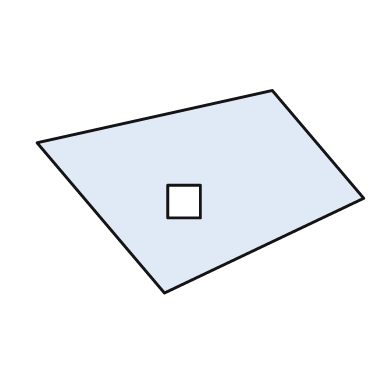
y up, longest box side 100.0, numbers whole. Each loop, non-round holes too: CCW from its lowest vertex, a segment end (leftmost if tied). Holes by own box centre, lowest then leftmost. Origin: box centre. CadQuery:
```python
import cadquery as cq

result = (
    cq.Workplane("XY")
    .moveTo(-11.0, -31.0)
    .lineTo(50.0, -2.0)
    .lineTo(22.0, 31.0)
    .lineTo(-50.0, 15.0)
    .close()
    .moveTo(-10.0, -8.0)
    .lineTo(0.0, -8.0)
    .lineTo(0.0, 2.0)
    .lineTo(-10.0, 2.0)
    .close()
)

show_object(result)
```